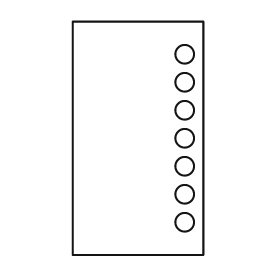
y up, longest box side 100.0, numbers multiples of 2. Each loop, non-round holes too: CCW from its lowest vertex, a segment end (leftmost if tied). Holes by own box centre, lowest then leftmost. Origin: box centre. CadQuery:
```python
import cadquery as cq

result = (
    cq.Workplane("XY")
    .moveTo(-28.0, -50.0)
    .lineTo(28.0, -50.0)
    .lineTo(28.0, 50.0)
    .lineTo(-28.0, 50.0)
    .close()
    .moveTo(20.0, -36.0)
    .circle(4.0)
    .moveTo(20.0, -24.0)
    .circle(4.0)
    .moveTo(20.0, -12.0)
    .circle(4.0)
    .moveTo(20.0, 0.0)
    .circle(4.0)
    .moveTo(20.0, 12.0)
    .circle(4.0)
    .moveTo(20.0, 24.0)
    .circle(4.0)
    .moveTo(20.0, 36.0)
    .circle(4.0)
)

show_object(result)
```